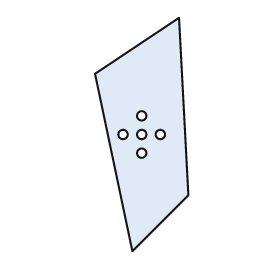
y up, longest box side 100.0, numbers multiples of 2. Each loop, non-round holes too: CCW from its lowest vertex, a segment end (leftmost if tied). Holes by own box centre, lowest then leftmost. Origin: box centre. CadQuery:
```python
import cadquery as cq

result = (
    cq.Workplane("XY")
    .moveTo(-4.0, -50.0)
    .lineTo(20.0, -26.0)
    .lineTo(16.0, 50.0)
    .lineTo(-20.0, 26.0)
    .close()
    .moveTo(0.0, -8.0)
    .circle(2.0)
    .moveTo(-8.0, 0.0)
    .circle(2.0)
    .moveTo(0.0, 0.0)
    .circle(2.0)
    .moveTo(8.0, 0.0)
    .circle(2.0)
    .moveTo(0.0, 8.0)
    .circle(2.0)
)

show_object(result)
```